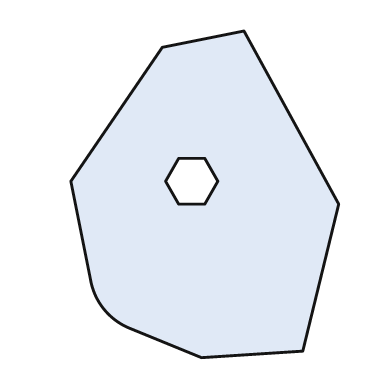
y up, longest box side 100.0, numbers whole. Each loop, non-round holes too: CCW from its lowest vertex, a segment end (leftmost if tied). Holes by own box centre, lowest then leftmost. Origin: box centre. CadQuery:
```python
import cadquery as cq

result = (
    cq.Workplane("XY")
    .moveTo(-1.0, -50.0)
    .lineTo(30.0, -48.0)
    .lineTo(41.0, -3.0)
    .lineTo(12.0, 50.0)
    .lineTo(-13.0, 45.0)
    .lineTo(-41.0, 4.0)
    .lineTo(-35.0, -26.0)
    .threePointArc((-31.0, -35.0), (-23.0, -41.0))
    .close()
    .moveTo(-8.0, -3.0)
    .lineTo(0.0, -3.0)
    .lineTo(4.0, 4.0)
    .lineTo(0.0, 11.0)
    .lineTo(-8.0, 11.0)
    .lineTo(-12.0, 4.0)
    .close()
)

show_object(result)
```